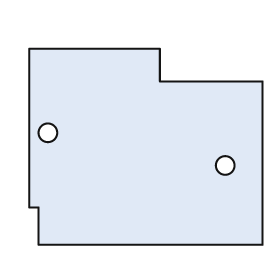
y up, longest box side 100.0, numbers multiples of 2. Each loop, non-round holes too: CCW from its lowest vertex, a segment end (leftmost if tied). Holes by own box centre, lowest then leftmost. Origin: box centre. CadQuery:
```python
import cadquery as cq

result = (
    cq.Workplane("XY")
    .moveTo(-46.0, -42.0)
    .lineTo(50.0, -42.0)
    .lineTo(50.0, 28.0)
    .lineTo(6.0, 28.0)
    .lineTo(6.0, 42.0)
    .lineTo(-50.0, 42.0)
    .lineTo(-50.0, -26.0)
    .lineTo(-46.0, -26.0)
    .close()
    .moveTo(34.0, -8.0)
    .circle(4.0)
    .moveTo(-42.0, 6.0)
    .circle(4.0)
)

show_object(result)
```